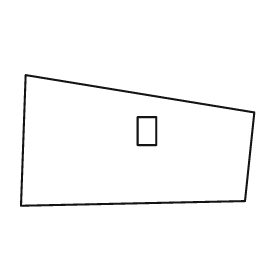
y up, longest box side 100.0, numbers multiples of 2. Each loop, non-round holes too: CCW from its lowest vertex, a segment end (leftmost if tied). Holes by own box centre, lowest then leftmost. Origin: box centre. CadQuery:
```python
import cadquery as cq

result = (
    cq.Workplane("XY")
    .moveTo(-50.0, -28.0)
    .lineTo(46.0, -26.0)
    .lineTo(50.0, 12.0)
    .lineTo(-48.0, 28.0)
    .close()
    .moveTo(0.0, -2.0)
    .lineTo(8.0, -2.0)
    .lineTo(8.0, 10.0)
    .lineTo(0.0, 10.0)
    .close()
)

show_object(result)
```